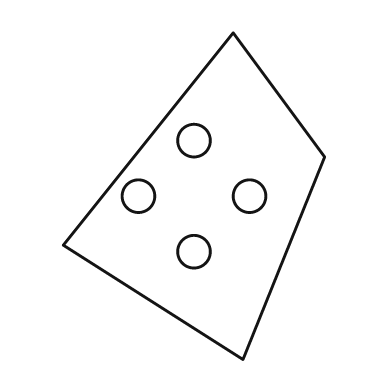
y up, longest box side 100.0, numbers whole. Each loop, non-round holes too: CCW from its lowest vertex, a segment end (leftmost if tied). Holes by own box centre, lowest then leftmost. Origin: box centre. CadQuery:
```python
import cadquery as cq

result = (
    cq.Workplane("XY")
    .moveTo(15.0, -50.0)
    .lineTo(40.0, 12.0)
    .lineTo(12.0, 50.0)
    .lineTo(-40.0, -15.0)
    .close()
    .moveTo(0.0, -17.0)
    .circle(5.0)
    .moveTo(-17.0, 0.0)
    .circle(5.0)
    .moveTo(17.0, 0.0)
    .circle(5.0)
    .moveTo(0.0, 17.0)
    .circle(5.0)
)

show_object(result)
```